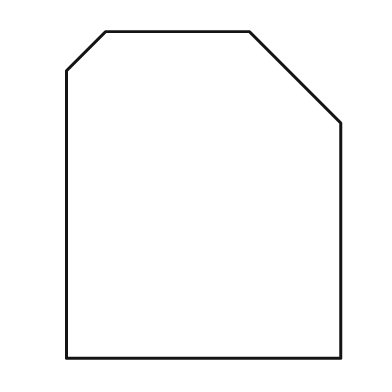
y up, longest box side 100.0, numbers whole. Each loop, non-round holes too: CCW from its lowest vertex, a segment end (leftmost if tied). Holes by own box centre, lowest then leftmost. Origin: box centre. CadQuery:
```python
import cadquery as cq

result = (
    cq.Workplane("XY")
    .moveTo(-42.0, -50.0)
    .lineTo(42.0, -50.0)
    .lineTo(42.0, 22.0)
    .lineTo(14.0, 50.0)
    .lineTo(-30.0, 50.0)
    .lineTo(-42.0, 38.0)
    .close()
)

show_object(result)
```